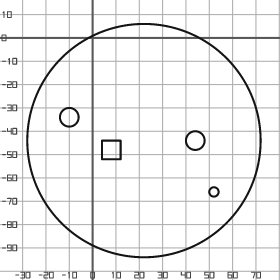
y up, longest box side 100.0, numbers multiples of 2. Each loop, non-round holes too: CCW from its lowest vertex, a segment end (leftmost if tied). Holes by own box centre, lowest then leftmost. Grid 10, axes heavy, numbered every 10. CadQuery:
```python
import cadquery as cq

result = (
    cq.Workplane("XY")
    .moveTo(22.0, -44.0)
    .circle(50.0)
    .moveTo(52.0, -66.0)
    .circle(2.0)
    .moveTo(4.0, -52.0)
    .lineTo(12.0, -52.0)
    .lineTo(12.0, -44.0)
    .lineTo(4.0, -44.0)
    .close()
    .moveTo(44.0, -44.0)
    .circle(4.0)
    .moveTo(-10.0, -34.0)
    .circle(4.0)
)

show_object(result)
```